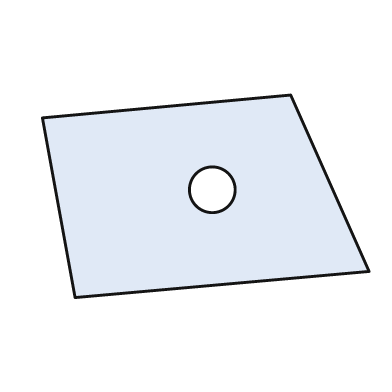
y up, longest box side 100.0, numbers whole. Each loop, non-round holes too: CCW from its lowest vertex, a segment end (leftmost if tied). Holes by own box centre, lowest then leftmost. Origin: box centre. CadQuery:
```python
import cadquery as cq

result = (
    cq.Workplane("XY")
    .moveTo(-40.0, -31.0)
    .lineTo(50.0, -23.0)
    .lineTo(26.0, 31.0)
    .lineTo(-50.0, 24.0)
    .close()
    .moveTo(2.0, 2.0)
    .circle(7.0)
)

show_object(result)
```